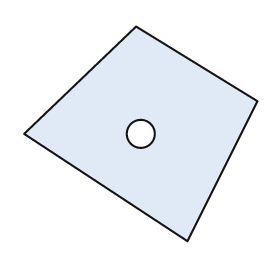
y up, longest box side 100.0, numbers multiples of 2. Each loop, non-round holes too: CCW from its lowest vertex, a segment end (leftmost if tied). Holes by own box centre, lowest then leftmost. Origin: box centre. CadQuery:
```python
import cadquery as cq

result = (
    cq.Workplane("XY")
    .moveTo(20.0, -46.0)
    .lineTo(50.0, 14.0)
    .lineTo(-2.0, 46.0)
    .lineTo(-50.0, 0.0)
    .close()
    .moveTo(0.0, 0.0)
    .circle(6.0)
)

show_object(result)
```